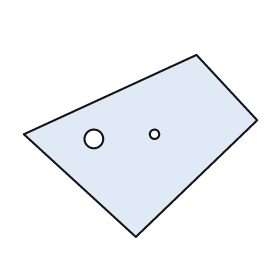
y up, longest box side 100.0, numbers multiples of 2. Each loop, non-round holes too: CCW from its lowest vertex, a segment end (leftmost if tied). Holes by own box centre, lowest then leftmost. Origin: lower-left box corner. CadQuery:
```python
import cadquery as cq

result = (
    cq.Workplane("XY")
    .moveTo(48.0, 0.0)
    .lineTo(100.0, 50.0)
    .lineTo(74.0, 78.0)
    .lineTo(0.0, 44.0)
    .close()
    .moveTo(30.0, 42.0)
    .circle(4.0)
    .moveTo(56.0, 44.0)
    .circle(2.0)
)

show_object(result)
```